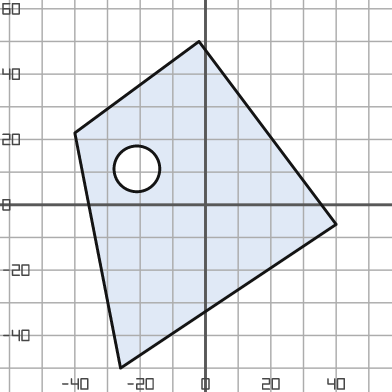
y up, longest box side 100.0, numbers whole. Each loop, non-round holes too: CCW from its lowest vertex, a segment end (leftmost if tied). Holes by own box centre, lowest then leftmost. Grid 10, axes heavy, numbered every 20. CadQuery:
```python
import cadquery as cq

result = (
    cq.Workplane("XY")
    .moveTo(-26.0, -50.0)
    .lineTo(40.0, -6.0)
    .lineTo(-2.0, 50.0)
    .lineTo(-40.0, 22.0)
    .close()
    .moveTo(-21.0, 11.0)
    .circle(7.0)
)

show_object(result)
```